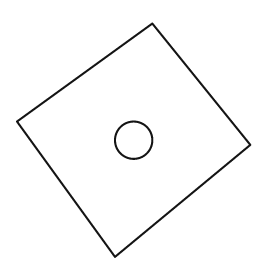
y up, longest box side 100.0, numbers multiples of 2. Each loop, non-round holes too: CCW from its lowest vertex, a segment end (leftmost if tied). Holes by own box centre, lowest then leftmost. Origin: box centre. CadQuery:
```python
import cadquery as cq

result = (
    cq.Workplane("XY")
    .moveTo(-8.0, -50.0)
    .lineTo(50.0, -2.0)
    .lineTo(8.0, 50.0)
    .lineTo(-50.0, 8.0)
    .close()
    .moveTo(0.0, 0.0)
    .circle(8.0)
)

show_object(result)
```